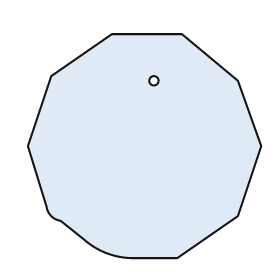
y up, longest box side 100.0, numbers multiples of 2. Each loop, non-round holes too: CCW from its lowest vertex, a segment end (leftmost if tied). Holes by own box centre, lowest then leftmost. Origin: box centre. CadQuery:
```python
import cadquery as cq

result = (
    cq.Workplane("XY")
    .moveTo(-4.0, -48.0)
    .lineTo(14.0, -48.0)
    .lineTo(40.0, -30.0)
    .lineTo(50.0, 0.0)
    .lineTo(40.0, 28.0)
    .lineTo(16.0, 48.0)
    .lineTo(-14.0, 48.0)
    .lineTo(-40.0, 30.0)
    .lineTo(-50.0, 0.0)
    .lineTo(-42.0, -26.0)
    .threePointArc((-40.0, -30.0), (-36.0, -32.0))
    .lineTo(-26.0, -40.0)
    .threePointArc((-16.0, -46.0), (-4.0, -48.0))
    .close()
    .moveTo(4.0, 28.0)
    .circle(2.0)
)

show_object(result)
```